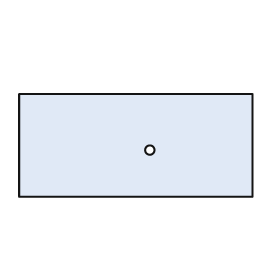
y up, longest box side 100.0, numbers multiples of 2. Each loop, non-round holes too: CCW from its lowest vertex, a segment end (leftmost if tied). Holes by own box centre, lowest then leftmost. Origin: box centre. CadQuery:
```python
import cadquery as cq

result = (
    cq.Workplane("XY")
    .moveTo(-50.0, -22.0)
    .lineTo(50.0, -22.0)
    .lineTo(50.0, 22.0)
    .lineTo(-50.0, 22.0)
    .close()
    .moveTo(6.0, -2.0)
    .circle(2.0)
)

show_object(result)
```